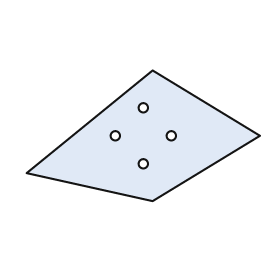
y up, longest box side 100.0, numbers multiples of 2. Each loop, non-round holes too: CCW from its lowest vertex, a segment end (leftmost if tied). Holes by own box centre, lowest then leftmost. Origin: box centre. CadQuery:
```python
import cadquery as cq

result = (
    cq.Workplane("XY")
    .moveTo(4.0, -28.0)
    .lineTo(50.0, 0.0)
    .lineTo(4.0, 28.0)
    .lineTo(-50.0, -16.0)
    .close()
    .moveTo(0.0, -12.0)
    .circle(2.0)
    .moveTo(-12.0, 0.0)
    .circle(2.0)
    .moveTo(12.0, 0.0)
    .circle(2.0)
    .moveTo(0.0, 12.0)
    .circle(2.0)
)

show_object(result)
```